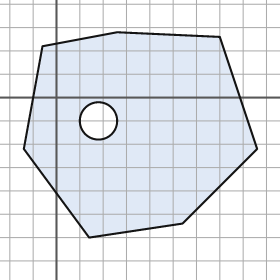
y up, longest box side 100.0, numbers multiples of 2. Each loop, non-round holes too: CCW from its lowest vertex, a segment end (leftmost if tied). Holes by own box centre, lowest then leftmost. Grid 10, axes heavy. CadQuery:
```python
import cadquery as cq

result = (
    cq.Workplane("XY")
    .moveTo(14.0, -60.0)
    .lineTo(54.0, -54.0)
    .lineTo(86.0, -22.0)
    .lineTo(70.0, 26.0)
    .lineTo(26.0, 28.0)
    .lineTo(-6.0, 22.0)
    .lineTo(-14.0, -22.0)
    .close()
    .moveTo(18.0, -10.0)
    .circle(8.0)
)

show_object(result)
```